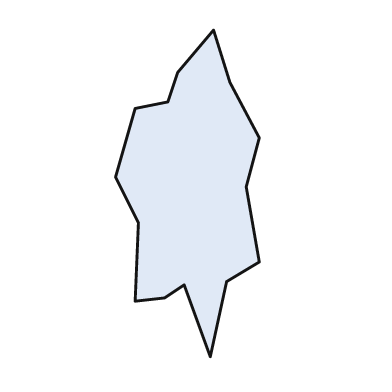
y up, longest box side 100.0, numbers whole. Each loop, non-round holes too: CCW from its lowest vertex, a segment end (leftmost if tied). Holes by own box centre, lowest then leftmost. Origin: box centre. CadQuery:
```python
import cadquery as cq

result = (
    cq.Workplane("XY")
    .moveTo(7.0, -50.0)
    .lineTo(12.0, -27.0)
    .lineTo(22.0, -21.0)
    .lineTo(18.0, 2.0)
    .lineTo(22.0, 17.0)
    .lineTo(13.0, 34.0)
    .lineTo(8.0, 50.0)
    .lineTo(-3.0, 37.0)
    .lineTo(-6.0, 28.0)
    .lineTo(-16.0, 26.0)
    .lineTo(-22.0, 5.0)
    .lineTo(-15.0, -9.0)
    .lineTo(-16.0, -33.0)
    .lineTo(-7.0, -32.0)
    .lineTo(-1.0, -28.0)
    .close()
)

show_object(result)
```